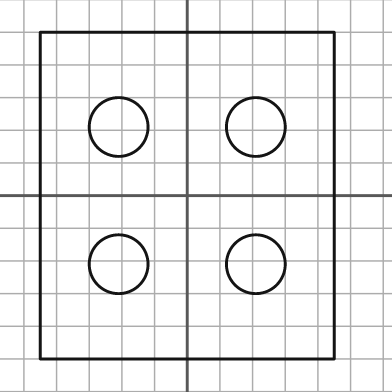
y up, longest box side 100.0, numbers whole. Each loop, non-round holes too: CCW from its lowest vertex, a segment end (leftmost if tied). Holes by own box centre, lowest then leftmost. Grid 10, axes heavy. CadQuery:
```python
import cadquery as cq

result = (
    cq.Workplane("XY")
    .moveTo(-45.0, -50.0)
    .lineTo(45.0, -50.0)
    .lineTo(45.0, 50.0)
    .lineTo(-45.0, 50.0)
    .close()
    .moveTo(-21.0, -21.0)
    .circle(9.0)
    .moveTo(21.0, -21.0)
    .circle(9.0)
    .moveTo(-21.0, 21.0)
    .circle(9.0)
    .moveTo(21.0, 21.0)
    .circle(9.0)
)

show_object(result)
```